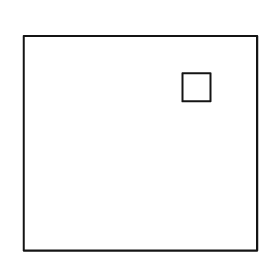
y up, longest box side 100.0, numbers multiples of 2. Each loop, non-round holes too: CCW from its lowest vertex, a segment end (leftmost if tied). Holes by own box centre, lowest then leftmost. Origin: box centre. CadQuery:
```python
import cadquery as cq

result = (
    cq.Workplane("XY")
    .moveTo(-50.0, -46.0)
    .lineTo(50.0, -46.0)
    .lineTo(50.0, 46.0)
    .lineTo(-50.0, 46.0)
    .close()
    .moveTo(18.0, 18.0)
    .lineTo(30.0, 18.0)
    .lineTo(30.0, 30.0)
    .lineTo(18.0, 30.0)
    .close()
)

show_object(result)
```